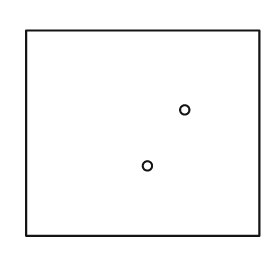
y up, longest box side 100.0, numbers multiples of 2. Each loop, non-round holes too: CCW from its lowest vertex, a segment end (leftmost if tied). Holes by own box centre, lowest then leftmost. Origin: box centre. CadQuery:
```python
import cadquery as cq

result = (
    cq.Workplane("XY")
    .moveTo(-50.0, -44.0)
    .lineTo(50.0, -44.0)
    .lineTo(50.0, 44.0)
    .lineTo(-50.0, 44.0)
    .close()
    .moveTo(2.0, -14.0)
    .circle(2.0)
    .moveTo(18.0, 10.0)
    .circle(2.0)
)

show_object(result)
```